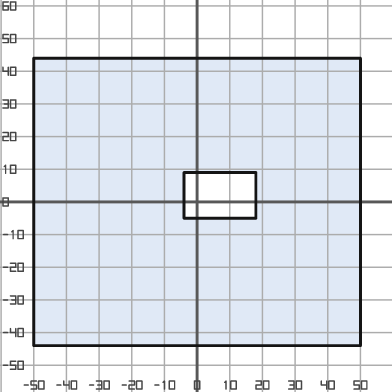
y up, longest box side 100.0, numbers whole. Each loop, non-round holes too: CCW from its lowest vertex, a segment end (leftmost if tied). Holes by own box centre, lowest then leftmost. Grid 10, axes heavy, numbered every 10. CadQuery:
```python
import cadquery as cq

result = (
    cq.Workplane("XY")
    .moveTo(-50.0, -44.0)
    .lineTo(50.0, -44.0)
    .lineTo(50.0, 44.0)
    .lineTo(-50.0, 44.0)
    .close()
    .moveTo(-4.0, -5.0)
    .lineTo(18.0, -5.0)
    .lineTo(18.0, 9.0)
    .lineTo(-4.0, 9.0)
    .close()
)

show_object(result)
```